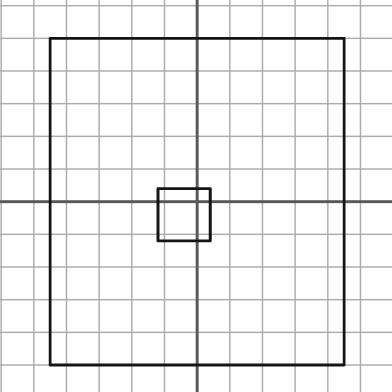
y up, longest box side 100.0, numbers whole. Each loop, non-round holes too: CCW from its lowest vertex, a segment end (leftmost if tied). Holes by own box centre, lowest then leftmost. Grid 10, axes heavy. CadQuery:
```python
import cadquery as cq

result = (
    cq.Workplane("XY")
    .moveTo(-45.0, -50.0)
    .lineTo(45.0, -50.0)
    .lineTo(45.0, 50.0)
    .lineTo(-45.0, 50.0)
    .close()
    .moveTo(-12.0, -12.0)
    .lineTo(4.0, -12.0)
    .lineTo(4.0, 4.0)
    .lineTo(-12.0, 4.0)
    .close()
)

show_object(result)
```